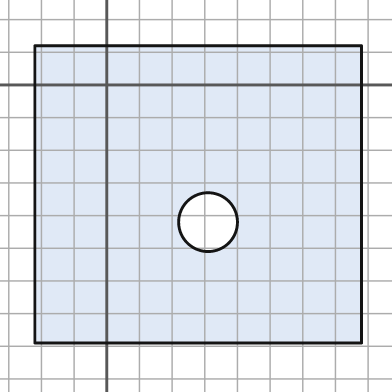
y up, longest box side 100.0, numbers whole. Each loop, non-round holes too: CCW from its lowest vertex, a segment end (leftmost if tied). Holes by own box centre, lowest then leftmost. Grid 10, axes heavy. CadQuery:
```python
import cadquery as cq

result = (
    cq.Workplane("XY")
    .moveTo(-22.0, -79.0)
    .lineTo(78.0, -79.0)
    .lineTo(78.0, 12.0)
    .lineTo(-22.0, 12.0)
    .close()
    .moveTo(31.0, -42.0)
    .circle(9.0)
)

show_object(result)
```